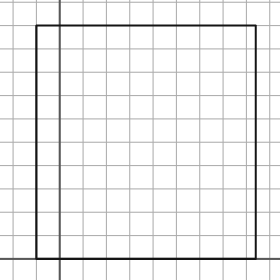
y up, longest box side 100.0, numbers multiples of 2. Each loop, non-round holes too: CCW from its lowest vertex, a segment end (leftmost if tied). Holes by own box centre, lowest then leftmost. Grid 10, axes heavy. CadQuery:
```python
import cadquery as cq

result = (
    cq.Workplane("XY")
    .moveTo(-10.0, 0.0)
    .lineTo(84.0, 0.0)
    .lineTo(84.0, 100.0)
    .lineTo(-10.0, 100.0)
    .close()
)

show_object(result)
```